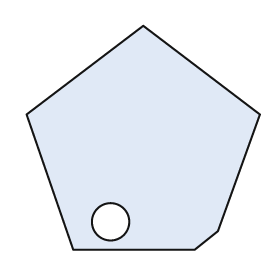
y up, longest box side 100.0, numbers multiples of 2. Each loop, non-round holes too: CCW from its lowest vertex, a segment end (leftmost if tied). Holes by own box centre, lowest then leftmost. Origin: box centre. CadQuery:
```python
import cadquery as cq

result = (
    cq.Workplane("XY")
    .moveTo(-30.0, -48.0)
    .lineTo(22.0, -48.0)
    .lineTo(32.0, -40.0)
    .lineTo(50.0, 10.0)
    .lineTo(0.0, 48.0)
    .lineTo(-50.0, 10.0)
    .close()
    .moveTo(-14.0, -36.0)
    .circle(8.0)
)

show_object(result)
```